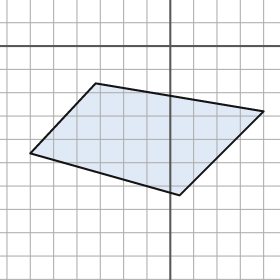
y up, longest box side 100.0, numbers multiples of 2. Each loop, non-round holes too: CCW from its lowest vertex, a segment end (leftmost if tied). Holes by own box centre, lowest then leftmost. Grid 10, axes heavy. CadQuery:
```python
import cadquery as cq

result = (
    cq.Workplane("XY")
    .moveTo(4.0, -64.0)
    .lineTo(40.0, -28.0)
    .lineTo(-32.0, -16.0)
    .lineTo(-60.0, -46.0)
    .close()
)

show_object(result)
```